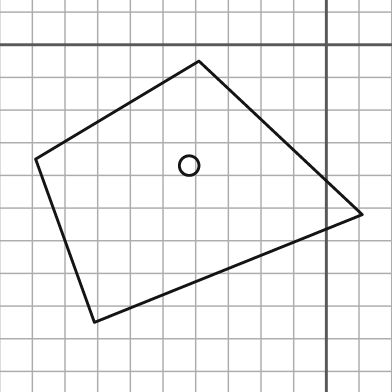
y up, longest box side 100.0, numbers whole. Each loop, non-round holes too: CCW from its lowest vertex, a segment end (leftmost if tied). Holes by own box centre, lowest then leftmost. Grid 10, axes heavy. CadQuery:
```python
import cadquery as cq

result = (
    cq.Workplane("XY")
    .moveTo(-71.0, -85.0)
    .lineTo(11.0, -52.0)
    .lineTo(-39.0, -5.0)
    .lineTo(-89.0, -35.0)
    .close()
    .moveTo(-42.0, -37.0)
    .circle(3.0)
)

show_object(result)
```